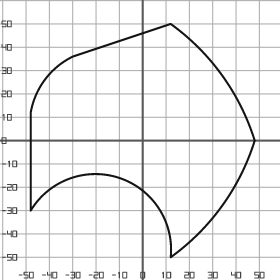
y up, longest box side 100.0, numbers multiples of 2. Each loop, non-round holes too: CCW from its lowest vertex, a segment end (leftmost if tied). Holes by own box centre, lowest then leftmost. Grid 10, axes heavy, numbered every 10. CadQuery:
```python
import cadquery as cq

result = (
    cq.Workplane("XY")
    .moveTo(12.0, -50.0)
    .threePointArc((34.0, -28.0), (48.0, 0.0))
    .threePointArc((34.0, 28.0), (12.0, 50.0))
    .lineTo(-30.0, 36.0)
    .threePointArc((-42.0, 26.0), (-48.0, 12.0))
    .lineTo(-48.0, -30.0)
    .threePointArc((-10.0, -16.0), (12.0, -50.0))
    .close()
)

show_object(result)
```